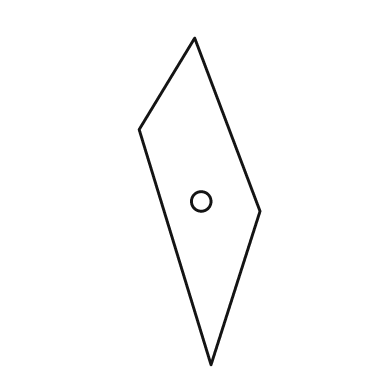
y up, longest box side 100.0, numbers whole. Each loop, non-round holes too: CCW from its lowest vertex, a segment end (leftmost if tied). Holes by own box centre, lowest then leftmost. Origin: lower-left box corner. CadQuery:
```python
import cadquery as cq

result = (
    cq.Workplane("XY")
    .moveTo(22.0, 0.0)
    .lineTo(37.0, 47.0)
    .lineTo(17.0, 100.0)
    .lineTo(0.0, 72.0)
    .close()
    .moveTo(19.0, 50.0)
    .circle(3.0)
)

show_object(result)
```